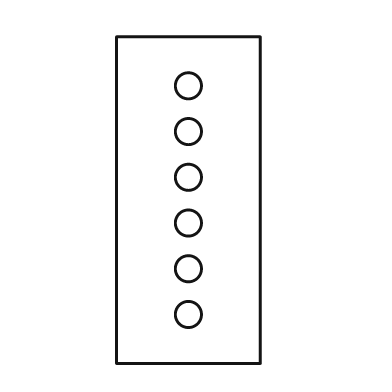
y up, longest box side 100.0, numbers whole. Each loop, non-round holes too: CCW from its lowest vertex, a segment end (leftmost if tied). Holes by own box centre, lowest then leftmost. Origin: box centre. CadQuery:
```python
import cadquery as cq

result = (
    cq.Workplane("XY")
    .moveTo(-22.0, -50.0)
    .lineTo(22.0, -50.0)
    .lineTo(22.0, 50.0)
    .lineTo(-22.0, 50.0)
    .close()
    .moveTo(0.0, -35.0)
    .circle(4.0)
    .moveTo(0.0, -21.0)
    .circle(4.0)
    .moveTo(0.0, -7.0)
    .circle(4.0)
    .moveTo(0.0, 7.0)
    .circle(4.0)
    .moveTo(0.0, 21.0)
    .circle(4.0)
    .moveTo(0.0, 35.0)
    .circle(4.0)
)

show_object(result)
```